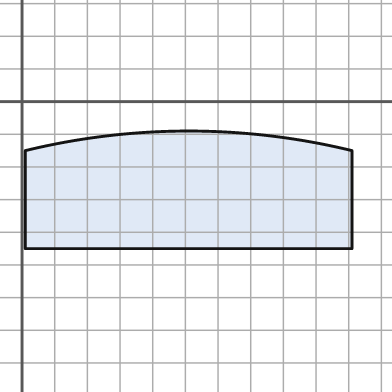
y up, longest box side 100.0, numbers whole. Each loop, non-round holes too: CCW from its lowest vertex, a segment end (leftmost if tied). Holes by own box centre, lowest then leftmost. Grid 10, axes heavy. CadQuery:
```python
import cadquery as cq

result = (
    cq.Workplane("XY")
    .moveTo(1.0, -45.0)
    .lineTo(101.0, -45.0)
    .lineTo(101.0, -15.0)
    .threePointArc((51.0, -9.0), (1.0, -15.0))
    .close()
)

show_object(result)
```